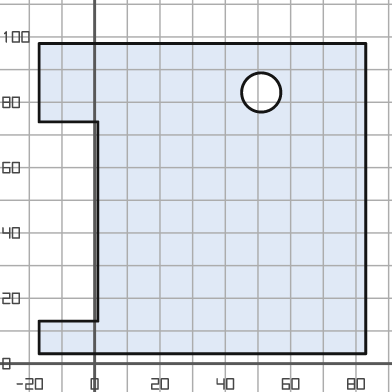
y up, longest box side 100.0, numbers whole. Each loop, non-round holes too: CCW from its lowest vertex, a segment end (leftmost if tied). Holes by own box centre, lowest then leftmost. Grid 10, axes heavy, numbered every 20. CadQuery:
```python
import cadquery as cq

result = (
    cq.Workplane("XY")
    .moveTo(-17.0, 3.0)
    .lineTo(83.0, 3.0)
    .lineTo(83.0, 98.0)
    .lineTo(-17.0, 98.0)
    .lineTo(-17.0, 74.0)
    .lineTo(1.0, 74.0)
    .lineTo(1.0, 13.0)
    .lineTo(-17.0, 13.0)
    .close()
    .moveTo(51.0, 83.0)
    .circle(6.0)
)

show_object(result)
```